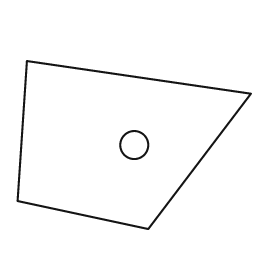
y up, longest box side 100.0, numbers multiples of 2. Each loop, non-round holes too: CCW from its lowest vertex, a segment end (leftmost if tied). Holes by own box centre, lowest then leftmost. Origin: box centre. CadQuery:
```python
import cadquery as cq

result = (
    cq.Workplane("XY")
    .moveTo(6.0, -36.0)
    .lineTo(50.0, 22.0)
    .lineTo(-46.0, 36.0)
    .lineTo(-50.0, -24.0)
    .close()
    .moveTo(0.0, 0.0)
    .circle(6.0)
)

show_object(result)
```